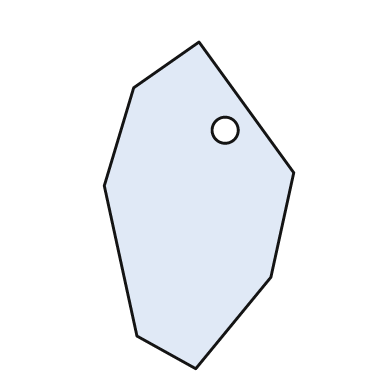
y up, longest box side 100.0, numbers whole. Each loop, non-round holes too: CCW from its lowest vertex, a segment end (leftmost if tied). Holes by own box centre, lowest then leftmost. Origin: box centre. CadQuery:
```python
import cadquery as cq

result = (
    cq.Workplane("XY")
    .moveTo(-1.0, -50.0)
    .lineTo(22.0, -22.0)
    .lineTo(29.0, 10.0)
    .lineTo(0.0, 50.0)
    .lineTo(-20.0, 36.0)
    .lineTo(-29.0, 6.0)
    .lineTo(-19.0, -40.0)
    .close()
    .moveTo(8.0, 23.0)
    .circle(4.0)
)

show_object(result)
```